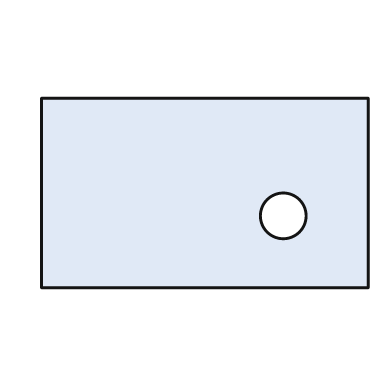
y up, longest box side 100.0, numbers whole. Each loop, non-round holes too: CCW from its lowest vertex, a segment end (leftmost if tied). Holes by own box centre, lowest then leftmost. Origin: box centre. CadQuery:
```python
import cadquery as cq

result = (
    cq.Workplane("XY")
    .moveTo(-50.0, -29.0)
    .lineTo(50.0, -29.0)
    .lineTo(50.0, 29.0)
    .lineTo(-50.0, 29.0)
    .close()
    .moveTo(24.0, -7.0)
    .circle(7.0)
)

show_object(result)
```